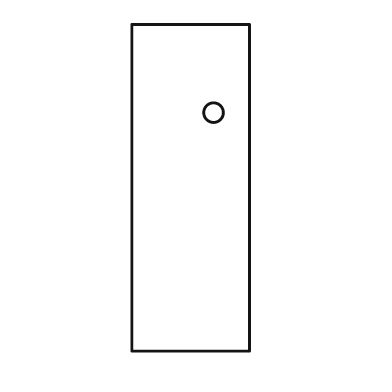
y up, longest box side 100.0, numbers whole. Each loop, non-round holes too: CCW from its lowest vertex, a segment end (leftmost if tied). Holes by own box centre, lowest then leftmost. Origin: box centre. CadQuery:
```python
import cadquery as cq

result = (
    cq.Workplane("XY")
    .moveTo(-18.0, -50.0)
    .lineTo(18.0, -50.0)
    .lineTo(18.0, 50.0)
    .lineTo(-18.0, 50.0)
    .close()
    .moveTo(7.0, 23.0)
    .circle(3.0)
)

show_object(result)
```